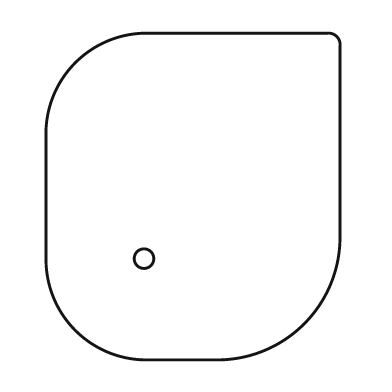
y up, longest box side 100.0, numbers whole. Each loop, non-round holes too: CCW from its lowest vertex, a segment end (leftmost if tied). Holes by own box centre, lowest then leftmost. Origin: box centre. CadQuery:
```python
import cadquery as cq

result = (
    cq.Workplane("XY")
    .moveTo(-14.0, -50.0)
    .lineTo(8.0, -50.0)
    .threePointArc((34.0, -39.0), (45.0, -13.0))
    .lineTo(45.0, 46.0)
    .threePointArc((44.0, 49.0), (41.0, 50.0))
    .lineTo(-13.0, 50.0)
    .threePointArc((-36.0, 41.0), (-45.0, 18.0))
    .lineTo(-45.0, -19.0)
    .threePointArc((-36.0, -41.0), (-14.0, -50.0))
    .close()
    .moveTo(-15.0, -19.0)
    .circle(3.0)
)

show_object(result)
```